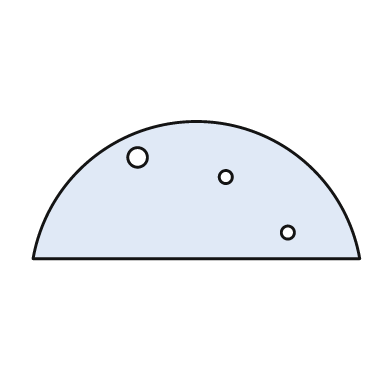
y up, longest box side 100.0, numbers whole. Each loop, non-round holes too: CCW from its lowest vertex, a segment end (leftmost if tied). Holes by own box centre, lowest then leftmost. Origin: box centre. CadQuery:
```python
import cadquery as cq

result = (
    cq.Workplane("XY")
    .moveTo(-50.0, -21.0)
    .lineTo(50.0, -21.0)
    .threePointArc((0.0, 21.0), (-50.0, -21.0))
    .close()
    .moveTo(28.0, -13.0)
    .circle(2.0)
    .moveTo(9.0, 4.0)
    .circle(2.0)
    .moveTo(-18.0, 10.0)
    .circle(3.0)
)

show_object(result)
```